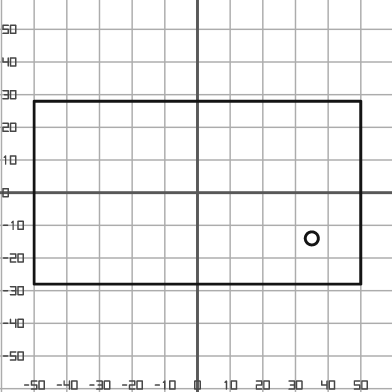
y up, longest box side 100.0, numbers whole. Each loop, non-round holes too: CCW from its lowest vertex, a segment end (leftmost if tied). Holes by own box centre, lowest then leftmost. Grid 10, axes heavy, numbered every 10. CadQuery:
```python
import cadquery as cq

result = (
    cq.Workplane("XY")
    .moveTo(-50.0, -28.0)
    .lineTo(50.0, -28.0)
    .lineTo(50.0, 28.0)
    .lineTo(-50.0, 28.0)
    .close()
    .moveTo(35.0, -14.0)
    .circle(2.0)
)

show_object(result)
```